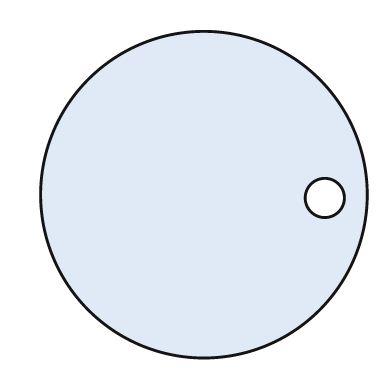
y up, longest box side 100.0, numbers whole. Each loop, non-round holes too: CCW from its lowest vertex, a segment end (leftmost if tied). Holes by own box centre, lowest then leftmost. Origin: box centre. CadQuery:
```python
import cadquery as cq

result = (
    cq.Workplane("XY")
    .moveTo(0.0, 0.0)
    .circle(50.0)
    .moveTo(37.0, -1.0)
    .circle(6.0)
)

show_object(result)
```